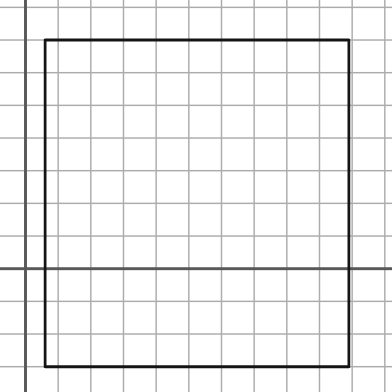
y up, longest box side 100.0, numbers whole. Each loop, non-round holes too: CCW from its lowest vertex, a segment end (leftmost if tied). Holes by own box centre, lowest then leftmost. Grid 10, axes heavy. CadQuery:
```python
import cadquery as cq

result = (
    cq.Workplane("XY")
    .moveTo(6.0, -30.0)
    .lineTo(99.0, -30.0)
    .lineTo(99.0, 70.0)
    .lineTo(6.0, 70.0)
    .close()
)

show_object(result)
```